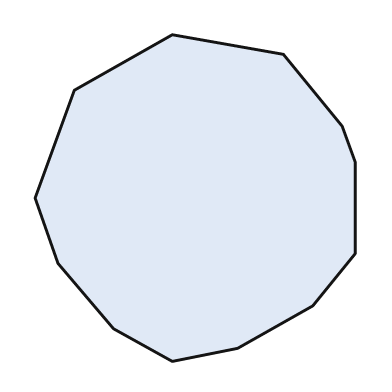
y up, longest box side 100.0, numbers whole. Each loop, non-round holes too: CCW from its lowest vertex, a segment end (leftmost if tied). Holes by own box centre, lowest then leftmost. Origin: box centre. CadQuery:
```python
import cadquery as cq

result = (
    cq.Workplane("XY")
    .moveTo(-7.0, -50.0)
    .lineTo(13.0, -46.0)
    .lineTo(36.0, -33.0)
    .lineTo(49.0, -17.0)
    .lineTo(49.0, 11.0)
    .lineTo(45.0, 22.0)
    .lineTo(27.0, 44.0)
    .lineTo(-7.0, 50.0)
    .lineTo(-37.0, 33.0)
    .lineTo(-49.0, 0.0)
    .lineTo(-42.0, -20.0)
    .lineTo(-25.0, -40.0)
    .close()
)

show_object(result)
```